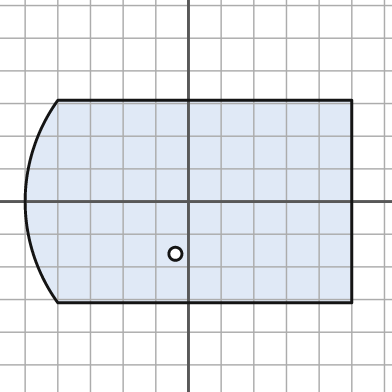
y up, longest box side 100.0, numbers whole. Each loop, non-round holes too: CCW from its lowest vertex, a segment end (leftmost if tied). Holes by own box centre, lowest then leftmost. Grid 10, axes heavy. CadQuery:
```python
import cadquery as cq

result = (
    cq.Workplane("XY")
    .moveTo(-40.0, -31.0)
    .lineTo(50.0, -31.0)
    .lineTo(50.0, 31.0)
    .lineTo(-40.0, 31.0)
    .threePointArc((-50.0, 0.0), (-40.0, -31.0))
    .close()
    .moveTo(-4.0, -16.0)
    .circle(2.0)
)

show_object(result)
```